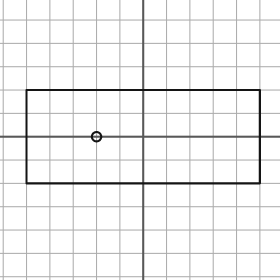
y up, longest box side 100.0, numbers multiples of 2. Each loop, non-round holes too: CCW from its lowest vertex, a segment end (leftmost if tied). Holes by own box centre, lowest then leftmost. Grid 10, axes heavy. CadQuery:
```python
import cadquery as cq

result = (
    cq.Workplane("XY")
    .moveTo(-50.0, -20.0)
    .lineTo(50.0, -20.0)
    .lineTo(50.0, 20.0)
    .lineTo(-50.0, 20.0)
    .close()
    .moveTo(-20.0, 0.0)
    .circle(2.0)
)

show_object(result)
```